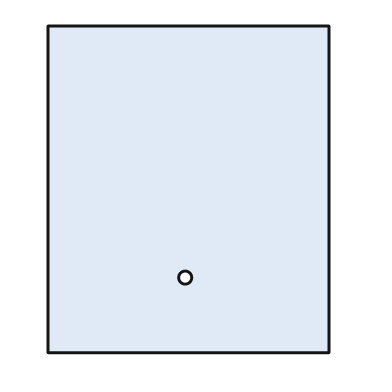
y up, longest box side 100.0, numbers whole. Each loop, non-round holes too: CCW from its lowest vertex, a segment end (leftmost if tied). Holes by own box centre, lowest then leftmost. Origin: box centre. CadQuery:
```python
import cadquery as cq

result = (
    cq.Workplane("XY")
    .moveTo(-43.0, -50.0)
    .lineTo(43.0, -50.0)
    .lineTo(43.0, 50.0)
    .lineTo(-43.0, 50.0)
    .close()
    .moveTo(-1.0, -27.0)
    .circle(2.0)
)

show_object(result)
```